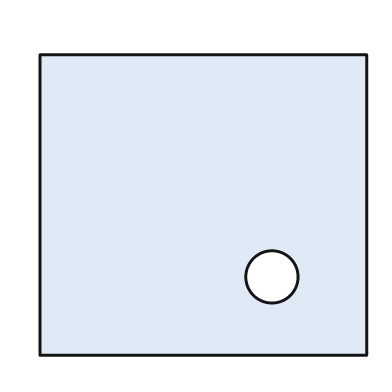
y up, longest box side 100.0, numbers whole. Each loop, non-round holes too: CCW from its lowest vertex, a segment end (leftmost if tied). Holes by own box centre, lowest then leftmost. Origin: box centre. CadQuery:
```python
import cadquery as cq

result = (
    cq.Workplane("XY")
    .moveTo(-50.0, -46.0)
    .lineTo(50.0, -46.0)
    .lineTo(50.0, 46.0)
    .lineTo(-50.0, 46.0)
    .close()
    .moveTo(21.0, -22.0)
    .circle(8.0)
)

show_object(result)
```